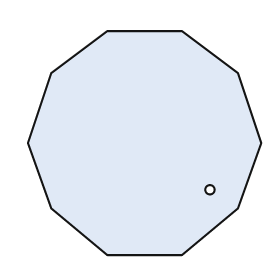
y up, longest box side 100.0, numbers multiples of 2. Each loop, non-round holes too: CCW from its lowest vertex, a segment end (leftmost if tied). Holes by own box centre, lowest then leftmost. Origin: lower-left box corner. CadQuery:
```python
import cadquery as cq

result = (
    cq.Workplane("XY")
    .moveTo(34.0, 0.0)
    .lineTo(66.0, 0.0)
    .lineTo(90.0, 20.0)
    .lineTo(100.0, 48.0)
    .lineTo(90.0, 78.0)
    .lineTo(66.0, 96.0)
    .lineTo(34.0, 96.0)
    .lineTo(10.0, 78.0)
    .lineTo(0.0, 48.0)
    .lineTo(10.0, 20.0)
    .close()
    .moveTo(78.0, 28.0)
    .circle(2.0)
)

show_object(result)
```